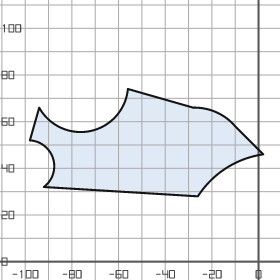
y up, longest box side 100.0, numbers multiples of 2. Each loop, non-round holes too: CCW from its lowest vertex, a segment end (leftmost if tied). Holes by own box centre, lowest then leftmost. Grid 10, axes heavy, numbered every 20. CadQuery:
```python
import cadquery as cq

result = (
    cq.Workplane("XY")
    .moveTo(-26.0, 28.0)
    .threePointArc((-14.0, 40.0), (2.0, 46.0))
    .lineTo(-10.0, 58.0)
    .threePointArc((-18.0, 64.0), (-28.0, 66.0))
    .lineTo(-56.0, 74.0)
    .threePointArc((-72.0, 56.0), (-94.0, 66.0))
    .lineTo(-98.0, 52.0)
    .threePointArc((-88.0, 44.0), (-92.0, 32.0))
    .close()
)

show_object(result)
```